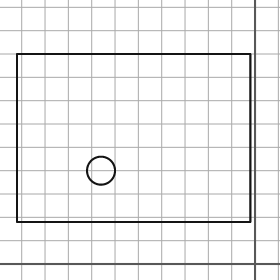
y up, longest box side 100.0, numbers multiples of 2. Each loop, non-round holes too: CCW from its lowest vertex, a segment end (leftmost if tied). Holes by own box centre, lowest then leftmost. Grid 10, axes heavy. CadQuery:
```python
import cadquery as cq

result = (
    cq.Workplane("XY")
    .moveTo(-102.0, 18.0)
    .lineTo(-2.0, 18.0)
    .lineTo(-2.0, 90.0)
    .lineTo(-102.0, 90.0)
    .close()
    .moveTo(-66.0, 40.0)
    .circle(6.0)
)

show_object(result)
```